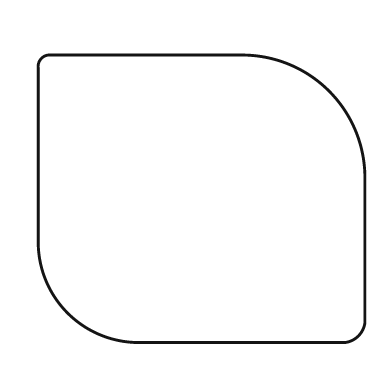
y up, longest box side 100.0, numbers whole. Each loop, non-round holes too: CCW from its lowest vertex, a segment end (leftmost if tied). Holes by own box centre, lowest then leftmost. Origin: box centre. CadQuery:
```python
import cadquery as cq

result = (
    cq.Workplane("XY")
    .moveTo(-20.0, -44.0)
    .lineTo(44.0, -44.0)
    .threePointArc((48.0, -42.0), (50.0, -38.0))
    .lineTo(50.0, 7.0)
    .threePointArc((39.0, 33.0), (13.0, 44.0))
    .lineTo(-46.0, 44.0)
    .threePointArc((-49.0, 43.0), (-50.0, 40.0))
    .lineTo(-50.0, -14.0)
    .threePointArc((-41.0, -35.0), (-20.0, -44.0))
    .close()
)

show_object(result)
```